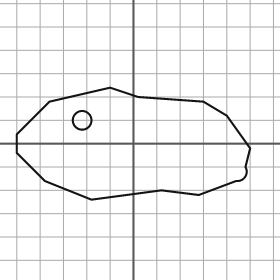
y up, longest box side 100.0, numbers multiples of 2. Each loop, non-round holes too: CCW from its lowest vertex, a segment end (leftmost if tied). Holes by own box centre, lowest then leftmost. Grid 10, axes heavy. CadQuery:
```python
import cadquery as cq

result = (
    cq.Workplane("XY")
    .moveTo(-18.0, -24.0)
    .lineTo(12.0, -20.0)
    .lineTo(28.0, -22.0)
    .lineTo(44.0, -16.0)
    .threePointArc((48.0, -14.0), (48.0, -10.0))
    .lineTo(50.0, -2.0)
    .lineTo(40.0, 12.0)
    .lineTo(30.0, 18.0)
    .lineTo(2.0, 20.0)
    .lineTo(-10.0, 24.0)
    .lineTo(-36.0, 18.0)
    .lineTo(-50.0, 4.0)
    .lineTo(-50.0, -4.0)
    .lineTo(-38.0, -16.0)
    .close()
    .moveTo(-22.0, 10.0)
    .circle(4.0)
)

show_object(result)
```